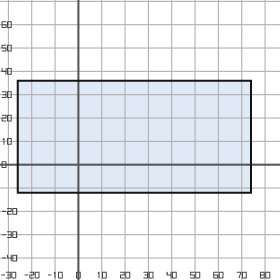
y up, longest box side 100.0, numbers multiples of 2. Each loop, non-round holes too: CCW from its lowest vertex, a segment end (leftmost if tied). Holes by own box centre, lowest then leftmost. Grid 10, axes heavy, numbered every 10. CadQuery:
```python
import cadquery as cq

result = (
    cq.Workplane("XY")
    .moveTo(-26.0, -12.0)
    .lineTo(74.0, -12.0)
    .lineTo(74.0, 36.0)
    .lineTo(-26.0, 36.0)
    .close()
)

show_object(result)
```